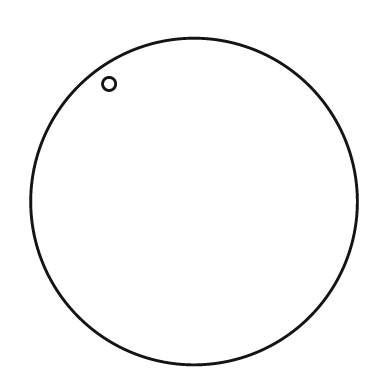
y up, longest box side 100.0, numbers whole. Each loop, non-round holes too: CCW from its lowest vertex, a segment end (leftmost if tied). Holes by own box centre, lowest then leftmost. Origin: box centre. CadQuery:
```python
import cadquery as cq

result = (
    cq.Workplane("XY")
    .moveTo(0.0, 0.0)
    .circle(50.0)
    .moveTo(-26.0, 36.0)
    .circle(2.0)
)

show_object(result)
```